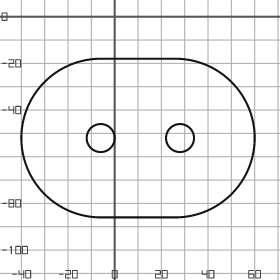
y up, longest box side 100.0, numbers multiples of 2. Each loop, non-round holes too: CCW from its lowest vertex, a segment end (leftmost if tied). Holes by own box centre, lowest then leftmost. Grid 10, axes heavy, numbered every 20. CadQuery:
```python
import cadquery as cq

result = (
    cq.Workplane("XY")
    .moveTo(-6.0, -86.0)
    .lineTo(26.0, -86.0)
    .threePointArc((60.0, -52.0), (26.0, -18.0))
    .lineTo(-6.0, -18.0)
    .threePointArc((-40.0, -52.0), (-6.0, -86.0))
    .close()
    .moveTo(-6.0, -52.0)
    .circle(6.0)
    .moveTo(28.0, -52.0)
    .circle(6.0)
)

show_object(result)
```